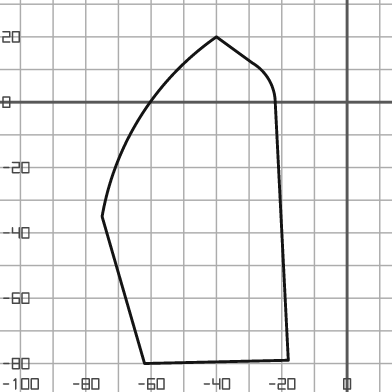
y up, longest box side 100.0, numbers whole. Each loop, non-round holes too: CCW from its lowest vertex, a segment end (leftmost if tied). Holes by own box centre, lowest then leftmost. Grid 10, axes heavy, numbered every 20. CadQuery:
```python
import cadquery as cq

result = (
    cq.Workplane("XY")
    .moveTo(-62.0, -80.0)
    .lineTo(-18.0, -79.0)
    .lineTo(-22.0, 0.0)
    .threePointArc((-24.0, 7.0), (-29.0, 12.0))
    .lineTo(-40.0, 20.0)
    .threePointArc((-63.0, -4.0), (-75.0, -35.0))
    .close()
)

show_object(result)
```